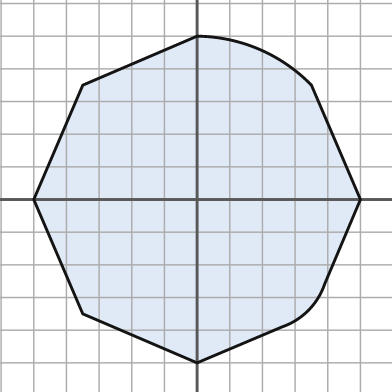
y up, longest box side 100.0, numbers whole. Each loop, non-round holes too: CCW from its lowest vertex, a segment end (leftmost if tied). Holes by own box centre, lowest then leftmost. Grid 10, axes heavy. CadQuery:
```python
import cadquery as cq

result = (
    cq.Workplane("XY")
    .moveTo(0.0, -50.0)
    .lineTo(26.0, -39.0)
    .threePointArc((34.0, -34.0), (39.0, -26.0))
    .lineTo(50.0, 0.0)
    .lineTo(35.0, 35.0)
    .threePointArc((19.0, 46.0), (0.0, 50.0))
    .lineTo(-35.0, 35.0)
    .lineTo(-50.0, 0.0)
    .lineTo(-35.0, -35.0)
    .close()
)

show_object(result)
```